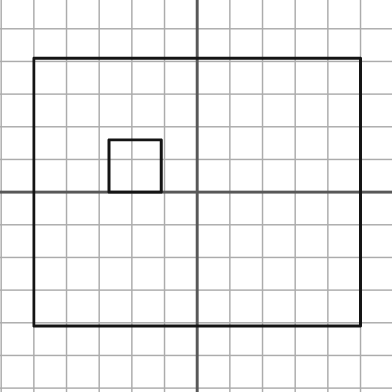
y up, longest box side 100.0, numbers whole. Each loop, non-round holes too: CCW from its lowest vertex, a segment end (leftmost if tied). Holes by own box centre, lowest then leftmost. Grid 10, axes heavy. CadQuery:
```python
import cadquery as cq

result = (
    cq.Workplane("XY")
    .moveTo(-50.0, -41.0)
    .lineTo(50.0, -41.0)
    .lineTo(50.0, 41.0)
    .lineTo(-50.0, 41.0)
    .close()
    .moveTo(-27.0, 0.0)
    .lineTo(-11.0, 0.0)
    .lineTo(-11.0, 16.0)
    .lineTo(-27.0, 16.0)
    .close()
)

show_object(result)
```